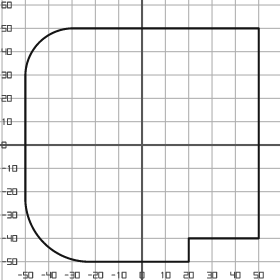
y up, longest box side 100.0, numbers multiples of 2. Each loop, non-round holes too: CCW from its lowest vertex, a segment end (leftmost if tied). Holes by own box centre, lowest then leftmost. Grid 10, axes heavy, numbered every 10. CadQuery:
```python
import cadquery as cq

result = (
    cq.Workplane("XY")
    .moveTo(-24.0, -50.0)
    .lineTo(20.0, -50.0)
    .lineTo(20.0, -40.0)
    .lineTo(50.0, -40.0)
    .lineTo(50.0, 50.0)
    .lineTo(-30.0, 50.0)
    .threePointArc((-44.0, 44.0), (-50.0, 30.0))
    .lineTo(-50.0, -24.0)
    .threePointArc((-42.0, -42.0), (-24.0, -50.0))
    .close()
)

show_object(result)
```